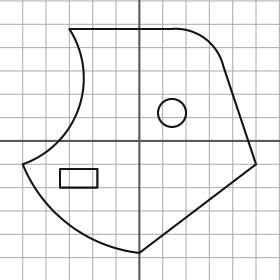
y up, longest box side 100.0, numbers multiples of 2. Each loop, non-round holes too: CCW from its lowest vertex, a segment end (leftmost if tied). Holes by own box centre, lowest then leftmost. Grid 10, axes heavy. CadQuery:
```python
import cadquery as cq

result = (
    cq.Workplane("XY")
    .moveTo(0.0, -48.0)
    .lineTo(50.0, -10.0)
    .lineTo(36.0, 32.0)
    .threePointArc((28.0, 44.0), (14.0, 48.0))
    .lineTo(-30.0, 48.0)
    .threePointArc((-26.0, 14.0), (-50.0, -10.0))
    .threePointArc((-30.0, -36.0), (0.0, -48.0))
    .close()
    .moveTo(-34.0, -20.0)
    .lineTo(-18.0, -20.0)
    .lineTo(-18.0, -12.0)
    .lineTo(-34.0, -12.0)
    .close()
    .moveTo(14.0, 12.0)
    .circle(6.0)
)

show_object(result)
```